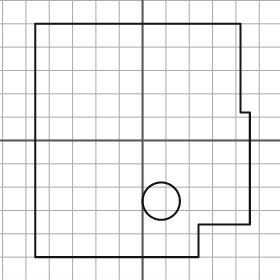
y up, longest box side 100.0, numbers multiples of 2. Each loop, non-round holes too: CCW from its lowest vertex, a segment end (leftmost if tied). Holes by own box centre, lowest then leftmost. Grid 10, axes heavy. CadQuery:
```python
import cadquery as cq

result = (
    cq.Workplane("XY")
    .moveTo(-46.0, -50.0)
    .lineTo(24.0, -50.0)
    .lineTo(24.0, -36.0)
    .lineTo(46.0, -36.0)
    .lineTo(46.0, 12.0)
    .lineTo(42.0, 12.0)
    .lineTo(42.0, 50.0)
    .lineTo(-46.0, 50.0)
    .close()
    .moveTo(8.0, -26.0)
    .circle(8.0)
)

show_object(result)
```